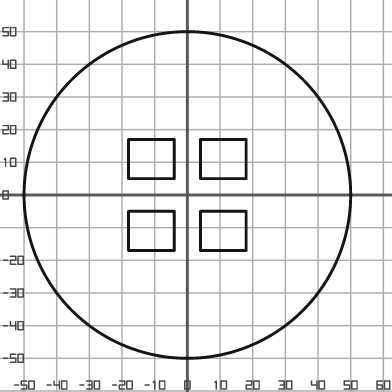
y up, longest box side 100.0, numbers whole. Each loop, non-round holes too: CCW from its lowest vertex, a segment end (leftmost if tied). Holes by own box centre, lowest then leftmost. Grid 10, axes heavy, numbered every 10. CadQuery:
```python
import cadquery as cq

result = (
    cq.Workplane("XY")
    .moveTo(0.0, 0.0)
    .circle(50.0)
    .moveTo(-18.0, -17.0)
    .lineTo(-4.0, -17.0)
    .lineTo(-4.0, -5.0)
    .lineTo(-18.0, -5.0)
    .close()
    .moveTo(4.0, -17.0)
    .lineTo(18.0, -17.0)
    .lineTo(18.0, -5.0)
    .lineTo(4.0, -5.0)
    .close()
    .moveTo(-18.0, 5.0)
    .lineTo(-4.0, 5.0)
    .lineTo(-4.0, 17.0)
    .lineTo(-18.0, 17.0)
    .close()
    .moveTo(4.0, 5.0)
    .lineTo(18.0, 5.0)
    .lineTo(18.0, 17.0)
    .lineTo(4.0, 17.0)
    .close()
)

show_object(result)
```